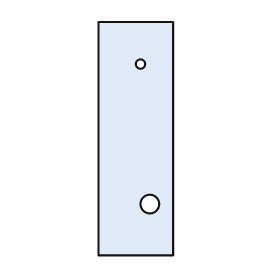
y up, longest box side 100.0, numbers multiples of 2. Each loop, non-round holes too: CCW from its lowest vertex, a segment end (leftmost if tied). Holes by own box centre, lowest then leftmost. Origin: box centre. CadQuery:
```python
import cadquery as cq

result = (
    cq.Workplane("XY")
    .moveTo(-16.0, -50.0)
    .lineTo(16.0, -50.0)
    .lineTo(16.0, 50.0)
    .lineTo(-16.0, 50.0)
    .close()
    .moveTo(6.0, -28.0)
    .circle(4.0)
    .moveTo(2.0, 32.0)
    .circle(2.0)
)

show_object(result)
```